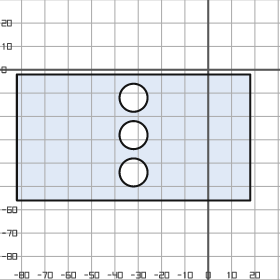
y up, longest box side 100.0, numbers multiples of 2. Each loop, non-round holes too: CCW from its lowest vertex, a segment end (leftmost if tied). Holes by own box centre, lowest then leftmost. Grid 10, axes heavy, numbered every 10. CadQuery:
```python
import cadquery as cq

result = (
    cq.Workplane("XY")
    .moveTo(-82.0, -56.0)
    .lineTo(18.0, -56.0)
    .lineTo(18.0, -2.0)
    .lineTo(-82.0, -2.0)
    .close()
    .moveTo(-32.0, -44.0)
    .circle(6.0)
    .moveTo(-32.0, -28.0)
    .circle(6.0)
    .moveTo(-32.0, -12.0)
    .circle(6.0)
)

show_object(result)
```